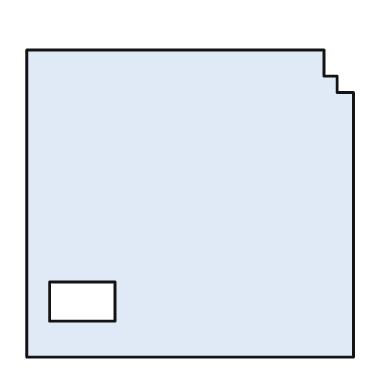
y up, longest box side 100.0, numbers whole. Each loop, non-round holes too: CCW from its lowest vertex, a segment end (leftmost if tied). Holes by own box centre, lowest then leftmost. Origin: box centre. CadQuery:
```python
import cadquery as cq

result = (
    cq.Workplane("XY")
    .moveTo(-50.0, -47.0)
    .lineTo(50.0, -47.0)
    .lineTo(50.0, 34.0)
    .lineTo(45.0, 34.0)
    .lineTo(45.0, 39.0)
    .lineTo(41.0, 39.0)
    .lineTo(41.0, 47.0)
    .lineTo(-50.0, 47.0)
    .close()
    .moveTo(-43.0, -36.0)
    .lineTo(-23.0, -36.0)
    .lineTo(-23.0, -24.0)
    .lineTo(-43.0, -24.0)
    .close()
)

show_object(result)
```